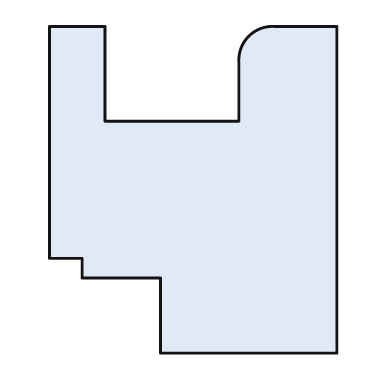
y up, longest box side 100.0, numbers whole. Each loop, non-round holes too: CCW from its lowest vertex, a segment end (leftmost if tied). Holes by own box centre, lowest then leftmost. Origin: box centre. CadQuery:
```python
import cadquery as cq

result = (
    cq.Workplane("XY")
    .moveTo(-10.0, -50.0)
    .lineTo(44.0, -50.0)
    .lineTo(44.0, 50.0)
    .lineTo(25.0, 50.0)
    .threePointArc((17.0, 47.0), (14.0, 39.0))
    .lineTo(14.0, 21.0)
    .lineTo(-27.0, 21.0)
    .lineTo(-27.0, 50.0)
    .lineTo(-44.0, 50.0)
    .lineTo(-44.0, -21.0)
    .lineTo(-34.0, -21.0)
    .lineTo(-34.0, -27.0)
    .lineTo(-10.0, -27.0)
    .close()
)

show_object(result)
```